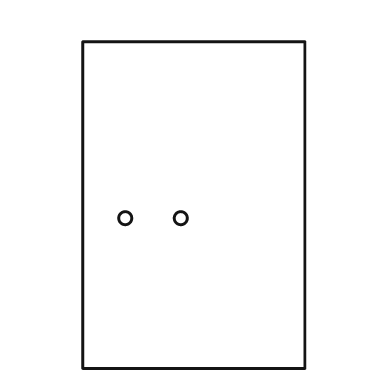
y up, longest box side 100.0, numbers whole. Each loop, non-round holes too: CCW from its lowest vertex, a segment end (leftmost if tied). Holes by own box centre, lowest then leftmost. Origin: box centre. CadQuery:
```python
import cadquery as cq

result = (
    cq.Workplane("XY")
    .moveTo(-34.0, -50.0)
    .lineTo(34.0, -50.0)
    .lineTo(34.0, 50.0)
    .lineTo(-34.0, 50.0)
    .close()
    .moveTo(-21.0, -4.0)
    .circle(2.0)
    .moveTo(-4.0, -4.0)
    .circle(2.0)
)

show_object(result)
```